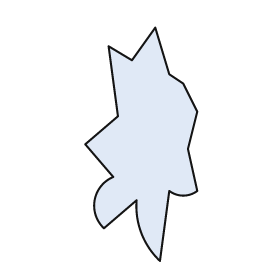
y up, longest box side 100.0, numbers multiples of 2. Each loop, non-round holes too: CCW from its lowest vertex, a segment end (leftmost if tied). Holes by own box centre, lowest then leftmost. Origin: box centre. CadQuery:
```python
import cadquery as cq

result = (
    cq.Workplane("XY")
    .moveTo(8.0, -50.0)
    .lineTo(12.0, -20.0)
    .threePointArc((18.0, -22.0), (24.0, -20.0))
    .lineTo(20.0, -2.0)
    .lineTo(24.0, 14.0)
    .lineTo(18.0, 26.0)
    .lineTo(12.0, 30.0)
    .lineTo(6.0, 50.0)
    .lineTo(-4.0, 36.0)
    .lineTo(-14.0, 42.0)
    .lineTo(-10.0, 12.0)
    .lineTo(-24.0, 0.0)
    .lineTo(-12.0, -14.0)
    .threePointArc((-20.0, -24.0), (-16.0, -36.0))
    .lineTo(-2.0, -24.0)
    .threePointArc((0.0, -38.0), (8.0, -50.0))
    .close()
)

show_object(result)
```